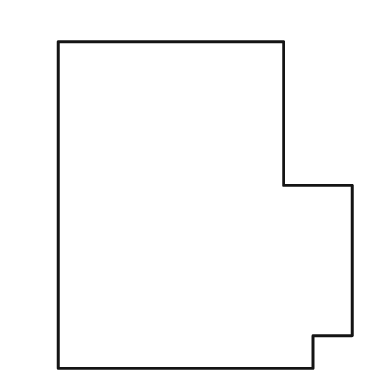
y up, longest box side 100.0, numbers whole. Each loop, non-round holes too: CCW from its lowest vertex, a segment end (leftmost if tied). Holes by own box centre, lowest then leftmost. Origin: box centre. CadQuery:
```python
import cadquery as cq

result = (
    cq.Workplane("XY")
    .moveTo(-45.0, -50.0)
    .lineTo(33.0, -50.0)
    .lineTo(33.0, -40.0)
    .lineTo(45.0, -40.0)
    .lineTo(45.0, 6.0)
    .lineTo(24.0, 6.0)
    .lineTo(24.0, 50.0)
    .lineTo(-45.0, 50.0)
    .close()
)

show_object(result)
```